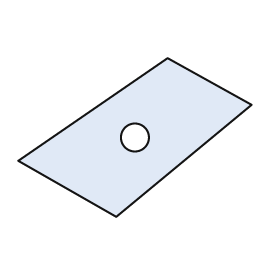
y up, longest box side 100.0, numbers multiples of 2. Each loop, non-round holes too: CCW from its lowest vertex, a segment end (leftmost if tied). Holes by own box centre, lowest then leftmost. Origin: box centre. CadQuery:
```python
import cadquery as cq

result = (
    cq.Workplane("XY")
    .moveTo(-8.0, -34.0)
    .lineTo(50.0, 14.0)
    .lineTo(14.0, 34.0)
    .lineTo(-50.0, -10.0)
    .close()
    .moveTo(0.0, 0.0)
    .circle(6.0)
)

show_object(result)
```